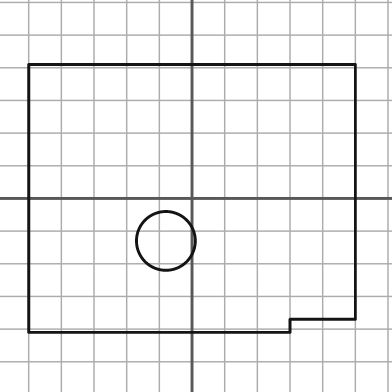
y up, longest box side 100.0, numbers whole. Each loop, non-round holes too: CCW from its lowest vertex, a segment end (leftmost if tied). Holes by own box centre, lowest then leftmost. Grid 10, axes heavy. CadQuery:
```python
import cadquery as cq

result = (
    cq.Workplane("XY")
    .moveTo(-50.0, -41.0)
    .lineTo(30.0, -41.0)
    .lineTo(30.0, -37.0)
    .lineTo(50.0, -37.0)
    .lineTo(50.0, 41.0)
    .lineTo(-50.0, 41.0)
    .close()
    .moveTo(-8.0, -13.0)
    .circle(9.0)
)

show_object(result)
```